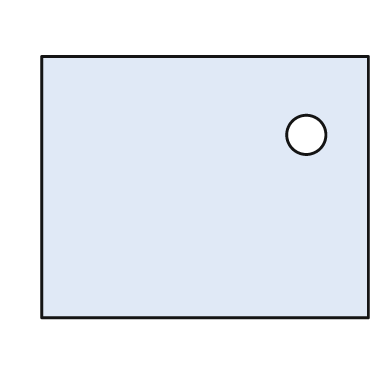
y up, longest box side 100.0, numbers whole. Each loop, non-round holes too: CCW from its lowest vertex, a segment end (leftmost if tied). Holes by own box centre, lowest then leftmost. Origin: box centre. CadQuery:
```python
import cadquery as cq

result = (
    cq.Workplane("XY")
    .moveTo(-50.0, -40.0)
    .lineTo(50.0, -40.0)
    .lineTo(50.0, 40.0)
    .lineTo(-50.0, 40.0)
    .close()
    .moveTo(31.0, 16.0)
    .circle(6.0)
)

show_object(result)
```